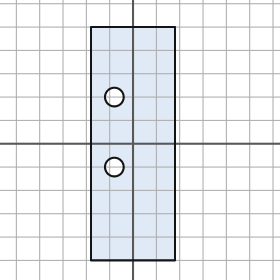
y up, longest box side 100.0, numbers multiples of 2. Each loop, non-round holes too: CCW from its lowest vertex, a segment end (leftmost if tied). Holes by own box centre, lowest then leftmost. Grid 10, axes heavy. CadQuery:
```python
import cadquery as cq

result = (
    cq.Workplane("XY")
    .moveTo(-18.0, -50.0)
    .lineTo(18.0, -50.0)
    .lineTo(18.0, 50.0)
    .lineTo(-18.0, 50.0)
    .close()
    .moveTo(-8.0, -10.0)
    .circle(4.0)
    .moveTo(-8.0, 20.0)
    .circle(4.0)
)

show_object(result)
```